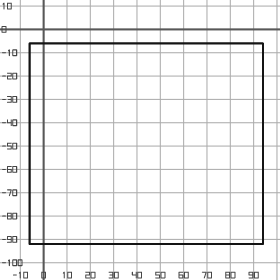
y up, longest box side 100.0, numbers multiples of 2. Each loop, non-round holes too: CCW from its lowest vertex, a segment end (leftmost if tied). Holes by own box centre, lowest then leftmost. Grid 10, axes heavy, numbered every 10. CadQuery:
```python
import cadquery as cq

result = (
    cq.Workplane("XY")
    .moveTo(-6.0, -92.0)
    .lineTo(94.0, -92.0)
    .lineTo(94.0, -6.0)
    .lineTo(-6.0, -6.0)
    .close()
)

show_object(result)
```